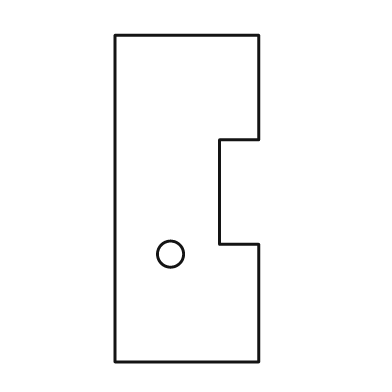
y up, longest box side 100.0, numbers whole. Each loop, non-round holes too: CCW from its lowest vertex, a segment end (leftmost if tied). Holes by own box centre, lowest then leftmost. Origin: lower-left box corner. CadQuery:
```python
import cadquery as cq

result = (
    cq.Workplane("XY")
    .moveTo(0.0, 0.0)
    .lineTo(44.0, 0.0)
    .lineTo(44.0, 36.0)
    .lineTo(32.0, 36.0)
    .lineTo(32.0, 68.0)
    .lineTo(44.0, 68.0)
    .lineTo(44.0, 100.0)
    .lineTo(0.0, 100.0)
    .close()
    .moveTo(17.0, 33.0)
    .circle(4.0)
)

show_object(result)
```